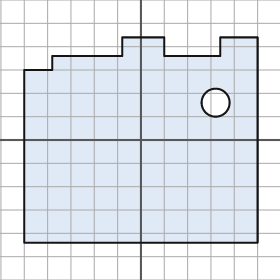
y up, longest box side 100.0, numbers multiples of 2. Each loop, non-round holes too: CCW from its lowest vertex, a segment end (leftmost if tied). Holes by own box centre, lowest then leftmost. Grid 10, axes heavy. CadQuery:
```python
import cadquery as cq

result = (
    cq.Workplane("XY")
    .moveTo(-50.0, -44.0)
    .lineTo(50.0, -44.0)
    .lineTo(50.0, 44.0)
    .lineTo(34.0, 44.0)
    .lineTo(34.0, 36.0)
    .lineTo(10.0, 36.0)
    .lineTo(10.0, 44.0)
    .lineTo(-8.0, 44.0)
    .lineTo(-8.0, 36.0)
    .lineTo(-38.0, 36.0)
    .lineTo(-38.0, 30.0)
    .lineTo(-50.0, 30.0)
    .close()
    .moveTo(32.0, 16.0)
    .circle(6.0)
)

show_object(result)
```